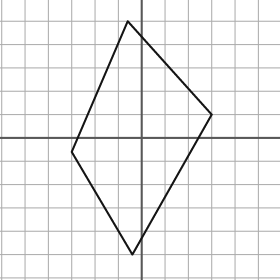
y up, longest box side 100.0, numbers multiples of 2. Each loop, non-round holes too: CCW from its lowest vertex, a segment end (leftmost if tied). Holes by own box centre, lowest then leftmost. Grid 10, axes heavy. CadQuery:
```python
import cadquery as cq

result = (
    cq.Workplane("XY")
    .moveTo(-4.0, -50.0)
    .lineTo(30.0, 10.0)
    .lineTo(-6.0, 50.0)
    .lineTo(-30.0, -6.0)
    .close()
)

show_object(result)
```